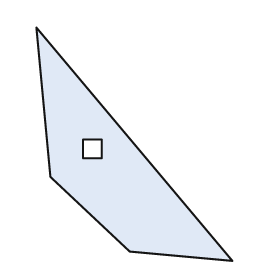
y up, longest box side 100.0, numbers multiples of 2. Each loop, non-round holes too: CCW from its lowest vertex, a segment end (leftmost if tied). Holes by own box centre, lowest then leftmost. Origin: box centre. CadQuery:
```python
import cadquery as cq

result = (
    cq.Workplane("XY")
    .moveTo(42.0, -50.0)
    .lineTo(-42.0, 50.0)
    .lineTo(-36.0, -14.0)
    .lineTo(-2.0, -46.0)
    .close()
    .moveTo(-22.0, -6.0)
    .lineTo(-14.0, -6.0)
    .lineTo(-14.0, 2.0)
    .lineTo(-22.0, 2.0)
    .close()
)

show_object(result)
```